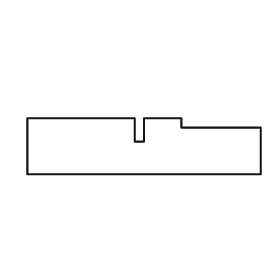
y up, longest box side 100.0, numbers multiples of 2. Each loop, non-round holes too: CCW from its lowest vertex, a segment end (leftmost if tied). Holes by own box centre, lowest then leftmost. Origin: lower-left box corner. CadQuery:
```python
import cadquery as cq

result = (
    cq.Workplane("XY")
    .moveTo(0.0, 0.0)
    .lineTo(100.0, 0.0)
    .lineTo(100.0, 20.0)
    .lineTo(66.0, 20.0)
    .lineTo(66.0, 24.0)
    .lineTo(50.0, 24.0)
    .lineTo(50.0, 14.0)
    .lineTo(46.0, 14.0)
    .lineTo(46.0, 24.0)
    .lineTo(0.0, 24.0)
    .close()
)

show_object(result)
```